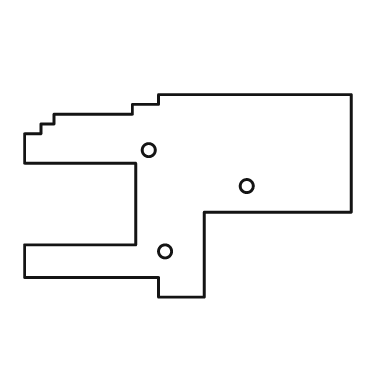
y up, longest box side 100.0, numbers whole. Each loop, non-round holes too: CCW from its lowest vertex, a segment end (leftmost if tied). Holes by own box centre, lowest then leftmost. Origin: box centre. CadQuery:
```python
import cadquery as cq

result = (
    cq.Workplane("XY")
    .moveTo(-9.0, -31.0)
    .lineTo(5.0, -31.0)
    .lineTo(5.0, -5.0)
    .lineTo(50.0, -5.0)
    .lineTo(50.0, 31.0)
    .lineTo(-9.0, 31.0)
    .lineTo(-9.0, 28.0)
    .lineTo(-17.0, 28.0)
    .lineTo(-17.0, 25.0)
    .lineTo(-41.0, 25.0)
    .lineTo(-41.0, 22.0)
    .lineTo(-45.0, 22.0)
    .lineTo(-45.0, 19.0)
    .lineTo(-50.0, 19.0)
    .lineTo(-50.0, 10.0)
    .lineTo(-16.0, 10.0)
    .lineTo(-16.0, -15.0)
    .lineTo(-50.0, -15.0)
    .lineTo(-50.0, -25.0)
    .lineTo(-9.0, -25.0)
    .close()
    .moveTo(-7.0, -17.0)
    .circle(2.0)
    .moveTo(18.0, 3.0)
    .circle(2.0)
    .moveTo(-12.0, 14.0)
    .circle(2.0)
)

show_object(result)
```